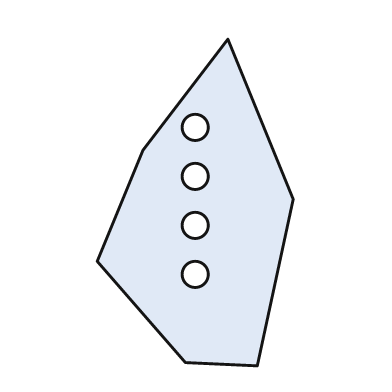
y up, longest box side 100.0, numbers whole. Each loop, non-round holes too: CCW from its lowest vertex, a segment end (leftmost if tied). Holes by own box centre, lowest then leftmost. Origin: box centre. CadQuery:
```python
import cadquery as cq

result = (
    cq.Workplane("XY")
    .moveTo(19.0, -50.0)
    .lineTo(30.0, 1.0)
    .lineTo(10.0, 50.0)
    .lineTo(-16.0, 16.0)
    .lineTo(-30.0, -18.0)
    .lineTo(-3.0, -49.0)
    .close()
    .moveTo(0.0, -22.0)
    .circle(4.0)
    .moveTo(0.0, -7.0)
    .circle(4.0)
    .moveTo(0.0, 8.0)
    .circle(4.0)
    .moveTo(0.0, 23.0)
    .circle(4.0)
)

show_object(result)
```